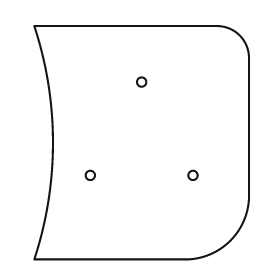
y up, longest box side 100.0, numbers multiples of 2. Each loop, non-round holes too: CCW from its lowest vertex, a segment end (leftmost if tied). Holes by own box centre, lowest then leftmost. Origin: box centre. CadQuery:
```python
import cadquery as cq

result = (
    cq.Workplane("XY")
    .moveTo(-46.0, -50.0)
    .lineTo(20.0, -50.0)
    .threePointArc((38.0, -42.0), (46.0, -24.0))
    .lineTo(46.0, 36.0)
    .threePointArc((42.0, 46.0), (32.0, 50.0))
    .lineTo(-46.0, 50.0)
    .threePointArc((-38.0, 0.0), (-46.0, -50.0))
    .close()
    .moveTo(-22.0, -14.0)
    .circle(2.0)
    .moveTo(22.0, -14.0)
    .circle(2.0)
    .moveTo(0.0, 26.0)
    .circle(2.0)
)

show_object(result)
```